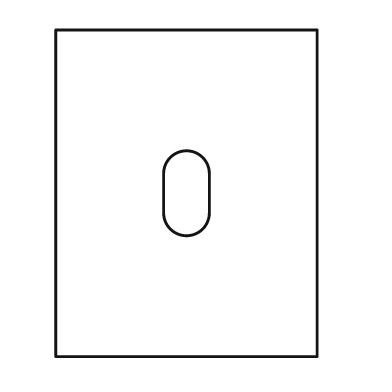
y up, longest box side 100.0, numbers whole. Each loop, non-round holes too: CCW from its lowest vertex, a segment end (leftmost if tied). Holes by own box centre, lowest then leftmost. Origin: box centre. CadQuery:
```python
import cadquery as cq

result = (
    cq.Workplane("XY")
    .moveTo(-40.0, -50.0)
    .lineTo(40.0, -50.0)
    .lineTo(40.0, 50.0)
    .lineTo(-40.0, 50.0)
    .close()
    .moveTo(-7.0, -6.0)
    .threePointArc((0.0, -13.0), (7.0, -6.0))
    .lineTo(7.0, 6.0)
    .threePointArc((0.0, 13.0), (-7.0, 6.0))
    .close()
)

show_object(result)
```